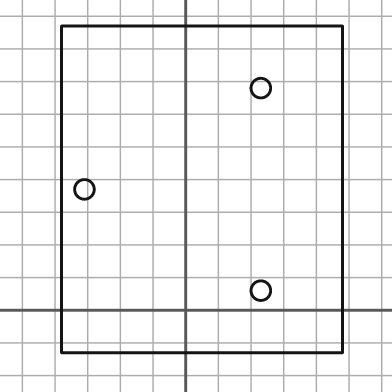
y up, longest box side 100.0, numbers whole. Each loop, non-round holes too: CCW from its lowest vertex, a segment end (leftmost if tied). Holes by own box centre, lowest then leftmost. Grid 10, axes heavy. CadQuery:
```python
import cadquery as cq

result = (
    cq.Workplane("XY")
    .moveTo(-38.0, -13.0)
    .lineTo(48.0, -13.0)
    .lineTo(48.0, 87.0)
    .lineTo(-38.0, 87.0)
    .close()
    .moveTo(23.0, 6.0)
    .circle(3.0)
    .moveTo(-31.0, 37.0)
    .circle(3.0)
    .moveTo(23.0, 68.0)
    .circle(3.0)
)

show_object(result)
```